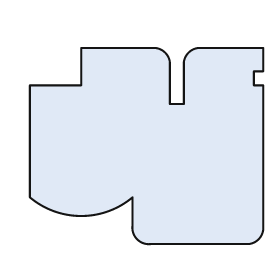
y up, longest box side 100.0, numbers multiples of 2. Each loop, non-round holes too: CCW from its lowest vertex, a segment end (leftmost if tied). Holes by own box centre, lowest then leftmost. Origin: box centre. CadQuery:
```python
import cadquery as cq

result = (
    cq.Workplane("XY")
    .moveTo(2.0, -42.0)
    .lineTo(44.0, -42.0)
    .threePointArc((48.0, -40.0), (50.0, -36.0))
    .lineTo(50.0, 26.0)
    .lineTo(46.0, 26.0)
    .lineTo(46.0, 32.0)
    .lineTo(50.0, 32.0)
    .lineTo(50.0, 42.0)
    .lineTo(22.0, 42.0)
    .threePointArc((18.0, 40.0), (16.0, 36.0))
    .lineTo(16.0, 18.0)
    .lineTo(10.0, 18.0)
    .lineTo(10.0, 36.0)
    .threePointArc((8.0, 40.0), (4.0, 42.0))
    .lineTo(-28.0, 42.0)
    .lineTo(-28.0, 26.0)
    .lineTo(-50.0, 26.0)
    .lineTo(-50.0, -22.0)
    .threePointArc((-28.0, -30.0), (-6.0, -22.0))
    .lineTo(-6.0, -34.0)
    .threePointArc((-4.0, -40.0), (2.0, -42.0))
    .close()
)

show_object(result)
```